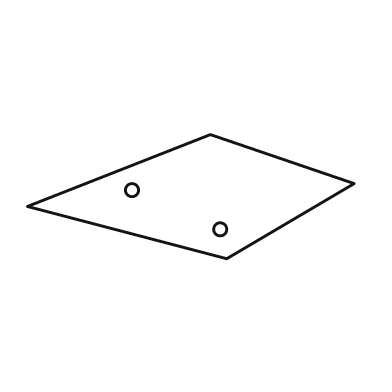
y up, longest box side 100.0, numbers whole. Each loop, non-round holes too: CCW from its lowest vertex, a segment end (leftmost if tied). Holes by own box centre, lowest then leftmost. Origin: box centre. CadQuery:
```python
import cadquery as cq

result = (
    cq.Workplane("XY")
    .moveTo(11.0, -19.0)
    .lineTo(50.0, 4.0)
    .lineTo(6.0, 19.0)
    .lineTo(-50.0, -3.0)
    .close()
    .moveTo(9.0, -10.0)
    .circle(2.0)
    .moveTo(-18.0, 2.0)
    .circle(2.0)
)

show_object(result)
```